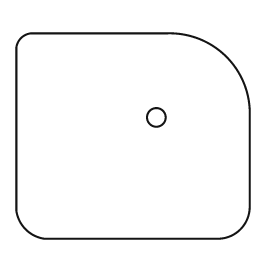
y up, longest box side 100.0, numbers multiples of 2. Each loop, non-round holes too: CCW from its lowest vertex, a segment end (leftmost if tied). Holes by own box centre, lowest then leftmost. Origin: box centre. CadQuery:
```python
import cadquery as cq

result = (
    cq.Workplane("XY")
    .moveTo(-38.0, -44.0)
    .lineTo(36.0, -44.0)
    .threePointArc((46.0, -40.0), (50.0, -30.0))
    .lineTo(50.0, 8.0)
    .threePointArc((40.0, 34.0), (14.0, 44.0))
    .lineTo(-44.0, 44.0)
    .threePointArc((-48.0, 42.0), (-50.0, 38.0))
    .lineTo(-50.0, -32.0)
    .threePointArc((-46.0, -40.0), (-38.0, -44.0))
    .close()
    .moveTo(10.0, 8.0)
    .circle(4.0)
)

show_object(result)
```